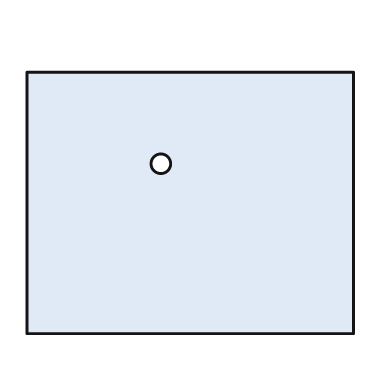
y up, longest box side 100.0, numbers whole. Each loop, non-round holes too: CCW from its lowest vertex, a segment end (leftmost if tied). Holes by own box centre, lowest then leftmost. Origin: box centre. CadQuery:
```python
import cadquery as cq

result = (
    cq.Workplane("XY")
    .moveTo(-50.0, -40.0)
    .lineTo(50.0, -40.0)
    .lineTo(50.0, 40.0)
    .lineTo(-50.0, 40.0)
    .close()
    .moveTo(-9.0, 12.0)
    .circle(3.0)
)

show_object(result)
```